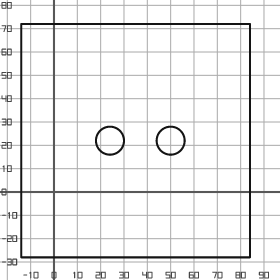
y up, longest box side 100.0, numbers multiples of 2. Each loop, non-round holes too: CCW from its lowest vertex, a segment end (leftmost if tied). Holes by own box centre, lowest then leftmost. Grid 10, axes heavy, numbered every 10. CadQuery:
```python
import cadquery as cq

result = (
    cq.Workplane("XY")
    .moveTo(-14.0, -28.0)
    .lineTo(84.0, -28.0)
    .lineTo(84.0, 72.0)
    .lineTo(-14.0, 72.0)
    .close()
    .moveTo(24.0, 22.0)
    .circle(6.0)
    .moveTo(50.0, 22.0)
    .circle(6.0)
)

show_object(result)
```